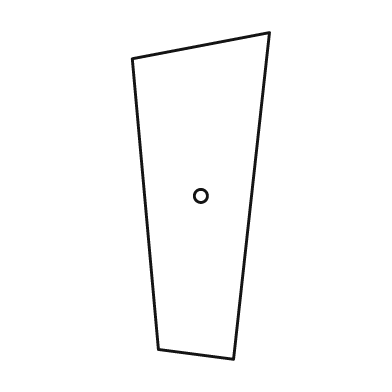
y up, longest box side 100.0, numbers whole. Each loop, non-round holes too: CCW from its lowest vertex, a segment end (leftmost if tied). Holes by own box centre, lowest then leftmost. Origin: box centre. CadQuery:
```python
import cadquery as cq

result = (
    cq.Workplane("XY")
    .moveTo(10.0, -50.0)
    .lineTo(21.0, 50.0)
    .lineTo(-21.0, 42.0)
    .lineTo(-13.0, -47.0)
    .close()
    .moveTo(0.0, 0.0)
    .circle(2.0)
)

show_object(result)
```